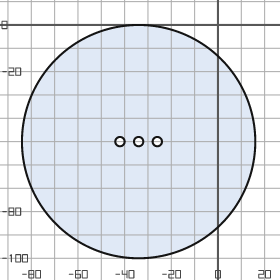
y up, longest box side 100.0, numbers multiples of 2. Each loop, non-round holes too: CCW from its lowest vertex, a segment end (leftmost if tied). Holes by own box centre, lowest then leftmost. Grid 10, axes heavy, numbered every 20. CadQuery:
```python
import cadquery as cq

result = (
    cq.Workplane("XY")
    .moveTo(-34.0, -50.0)
    .circle(50.0)
    .moveTo(-42.0, -50.0)
    .circle(2.0)
    .moveTo(-34.0, -50.0)
    .circle(2.0)
    .moveTo(-26.0, -50.0)
    .circle(2.0)
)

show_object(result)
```